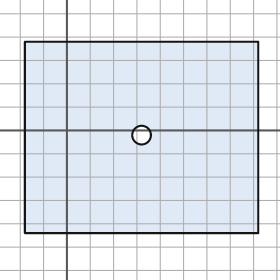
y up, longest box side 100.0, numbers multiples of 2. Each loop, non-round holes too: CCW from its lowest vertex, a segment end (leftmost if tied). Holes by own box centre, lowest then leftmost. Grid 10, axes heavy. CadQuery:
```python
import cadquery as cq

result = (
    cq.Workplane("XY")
    .moveTo(-18.0, -44.0)
    .lineTo(82.0, -44.0)
    .lineTo(82.0, 38.0)
    .lineTo(-18.0, 38.0)
    .close()
    .moveTo(32.0, -2.0)
    .circle(4.0)
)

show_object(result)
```